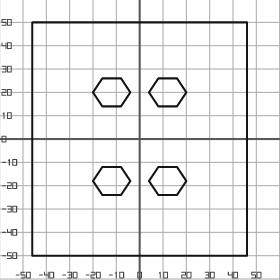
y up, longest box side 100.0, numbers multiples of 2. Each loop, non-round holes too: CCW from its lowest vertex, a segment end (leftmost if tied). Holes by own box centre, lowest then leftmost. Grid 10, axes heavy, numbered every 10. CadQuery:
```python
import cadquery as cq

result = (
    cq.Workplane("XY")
    .moveTo(-46.0, -50.0)
    .lineTo(46.0, -50.0)
    .lineTo(46.0, 50.0)
    .lineTo(-46.0, 50.0)
    .close()
    .moveTo(-16.0, -24.0)
    .lineTo(-8.0, -24.0)
    .lineTo(-4.0, -18.0)
    .lineTo(-8.0, -12.0)
    .lineTo(-16.0, -12.0)
    .lineTo(-20.0, -18.0)
    .close()
    .moveTo(8.0, -24.0)
    .lineTo(16.0, -24.0)
    .lineTo(20.0, -18.0)
    .lineTo(16.0, -12.0)
    .lineTo(8.0, -12.0)
    .lineTo(4.0, -18.0)
    .close()
    .moveTo(-16.0, 14.0)
    .lineTo(-8.0, 14.0)
    .lineTo(-4.0, 20.0)
    .lineTo(-8.0, 26.0)
    .lineTo(-16.0, 26.0)
    .lineTo(-20.0, 20.0)
    .close()
    .moveTo(8.0, 14.0)
    .lineTo(16.0, 14.0)
    .lineTo(20.0, 20.0)
    .lineTo(16.0, 26.0)
    .lineTo(8.0, 26.0)
    .lineTo(4.0, 20.0)
    .close()
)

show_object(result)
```